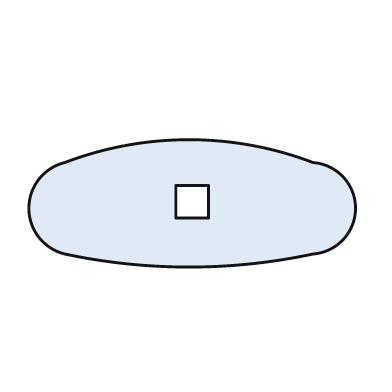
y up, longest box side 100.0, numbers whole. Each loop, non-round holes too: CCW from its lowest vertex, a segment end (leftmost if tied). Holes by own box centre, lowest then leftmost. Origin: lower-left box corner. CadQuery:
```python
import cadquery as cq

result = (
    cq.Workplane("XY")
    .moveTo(11.0, 4.0)
    .threePointArc((49.0, 0.0), (87.0, 4.0))
    .threePointArc((100.0, 18.0), (87.0, 32.0))
    .threePointArc((49.0, 39.0), (11.0, 32.0))
    .threePointArc((0.0, 18.0), (11.0, 4.0))
    .close()
    .moveTo(45.0, 15.0)
    .lineTo(55.0, 15.0)
    .lineTo(55.0, 25.0)
    .lineTo(45.0, 25.0)
    .close()
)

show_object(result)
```